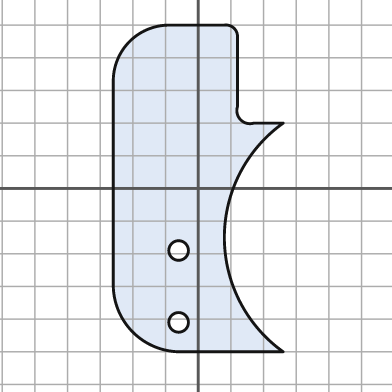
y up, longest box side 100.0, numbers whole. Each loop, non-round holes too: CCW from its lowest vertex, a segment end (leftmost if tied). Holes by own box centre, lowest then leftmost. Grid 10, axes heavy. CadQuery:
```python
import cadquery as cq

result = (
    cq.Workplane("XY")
    .moveTo(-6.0, -50.0)
    .lineTo(26.0, -50.0)
    .threePointArc((8.0, -15.0), (26.0, 20.0))
    .lineTo(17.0, 20.0)
    .threePointArc((13.0, 21.0), (12.0, 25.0))
    .lineTo(12.0, 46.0)
    .threePointArc((11.0, 49.0), (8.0, 50.0))
    .lineTo(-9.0, 50.0)
    .threePointArc((-21.0, 45.0), (-26.0, 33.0))
    .lineTo(-26.0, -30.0)
    .threePointArc((-20.0, -44.0), (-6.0, -50.0))
    .close()
    .moveTo(-6.0, -41.0)
    .circle(3.0)
    .moveTo(-6.0, -19.0)
    .circle(3.0)
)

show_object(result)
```